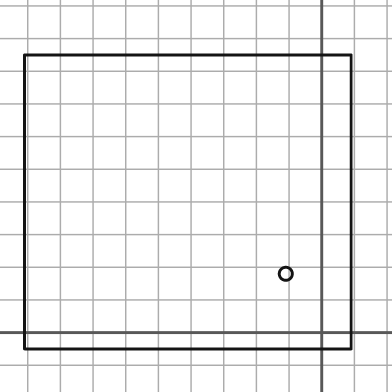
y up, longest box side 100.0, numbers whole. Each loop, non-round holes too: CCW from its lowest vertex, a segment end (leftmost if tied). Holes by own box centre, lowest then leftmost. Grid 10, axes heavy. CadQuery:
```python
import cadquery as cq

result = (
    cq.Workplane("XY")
    .moveTo(-91.0, -5.0)
    .lineTo(9.0, -5.0)
    .lineTo(9.0, 85.0)
    .lineTo(-91.0, 85.0)
    .close()
    .moveTo(-11.0, 18.0)
    .circle(2.0)
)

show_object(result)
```